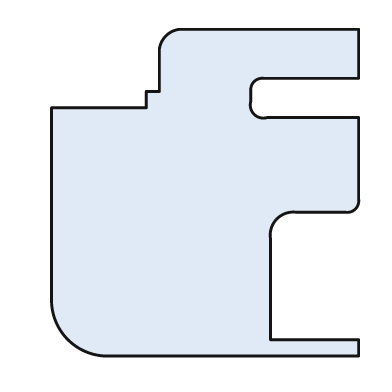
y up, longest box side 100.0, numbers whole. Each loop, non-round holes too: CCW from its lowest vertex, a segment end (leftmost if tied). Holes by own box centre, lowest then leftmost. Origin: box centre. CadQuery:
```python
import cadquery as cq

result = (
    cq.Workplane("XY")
    .moveTo(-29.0, -50.0)
    .lineTo(47.0, -50.0)
    .lineTo(47.0, -45.0)
    .lineTo(20.0, -45.0)
    .lineTo(20.0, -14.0)
    .threePointArc((22.0, -8.0), (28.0, -6.0))
    .lineTo(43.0, -6.0)
    .threePointArc((46.0, -5.0), (47.0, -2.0))
    .lineTo(47.0, 23.0)
    .lineTo(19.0, 23.0)
    .threePointArc((15.0, 24.0), (14.0, 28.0))
    .lineTo(14.0, 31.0)
    .threePointArc((15.0, 34.0), (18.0, 35.0))
    .lineTo(47.0, 35.0)
    .lineTo(47.0, 50.0)
    .lineTo(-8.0, 50.0)
    .threePointArc((-12.0, 48.0), (-14.0, 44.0))
    .lineTo(-14.0, 31.0)
    .lineTo(-18.0, 31.0)
    .lineTo(-18.0, 26.0)
    .lineTo(-47.0, 26.0)
    .lineTo(-47.0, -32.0)
    .threePointArc((-42.0, -45.0), (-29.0, -50.0))
    .close()
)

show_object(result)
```